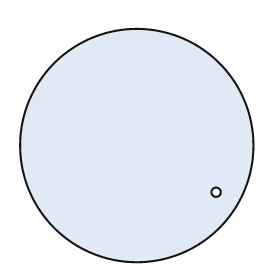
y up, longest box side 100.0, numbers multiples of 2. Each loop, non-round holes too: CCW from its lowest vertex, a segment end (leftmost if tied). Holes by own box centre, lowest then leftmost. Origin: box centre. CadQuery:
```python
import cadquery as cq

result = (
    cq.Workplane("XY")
    .moveTo(0.0, 0.0)
    .circle(50.0)
    .moveTo(34.0, -20.0)
    .circle(2.0)
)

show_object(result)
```